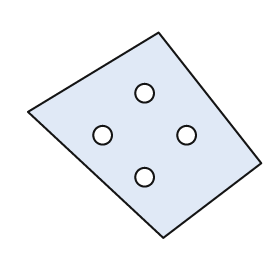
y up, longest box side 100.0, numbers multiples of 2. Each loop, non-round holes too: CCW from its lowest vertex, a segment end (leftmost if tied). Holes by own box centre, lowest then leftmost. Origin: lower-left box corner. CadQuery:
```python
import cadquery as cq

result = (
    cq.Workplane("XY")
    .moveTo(58.0, 0.0)
    .lineTo(100.0, 32.0)
    .lineTo(56.0, 88.0)
    .lineTo(0.0, 54.0)
    .close()
    .moveTo(50.0, 26.0)
    .circle(4.0)
    .moveTo(32.0, 44.0)
    .circle(4.0)
    .moveTo(68.0, 44.0)
    .circle(4.0)
    .moveTo(50.0, 62.0)
    .circle(4.0)
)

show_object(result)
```